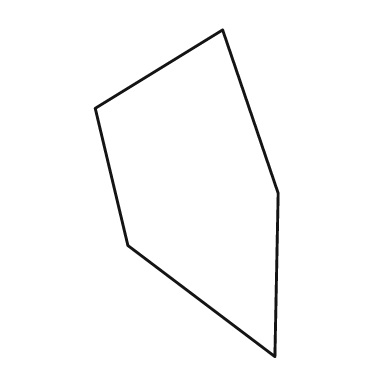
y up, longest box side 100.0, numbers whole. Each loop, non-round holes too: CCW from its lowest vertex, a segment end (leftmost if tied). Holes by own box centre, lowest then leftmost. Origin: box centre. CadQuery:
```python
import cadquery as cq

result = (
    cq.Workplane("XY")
    .moveTo(27.0, -50.0)
    .lineTo(28.0, 0.0)
    .lineTo(11.0, 50.0)
    .lineTo(-28.0, 26.0)
    .lineTo(-18.0, -16.0)
    .close()
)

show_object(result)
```